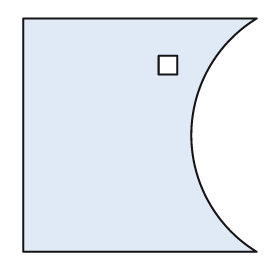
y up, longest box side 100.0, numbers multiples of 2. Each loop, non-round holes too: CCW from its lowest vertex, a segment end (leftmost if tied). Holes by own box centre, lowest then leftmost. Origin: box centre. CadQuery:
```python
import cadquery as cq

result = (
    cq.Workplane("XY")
    .moveTo(-50.0, -50.0)
    .lineTo(50.0, -50.0)
    .threePointArc((22.0, 0.0), (50.0, 50.0))
    .lineTo(-50.0, 50.0)
    .close()
    .moveTo(8.0, 26.0)
    .lineTo(16.0, 26.0)
    .lineTo(16.0, 34.0)
    .lineTo(8.0, 34.0)
    .close()
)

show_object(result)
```